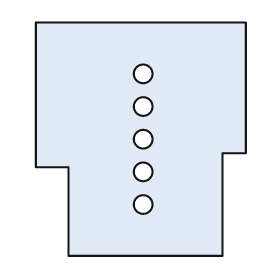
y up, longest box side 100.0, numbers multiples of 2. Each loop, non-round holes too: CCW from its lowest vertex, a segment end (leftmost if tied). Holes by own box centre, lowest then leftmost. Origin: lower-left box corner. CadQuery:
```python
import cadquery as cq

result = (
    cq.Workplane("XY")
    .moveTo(14.0, 0.0)
    .lineTo(80.0, 0.0)
    .lineTo(80.0, 44.0)
    .lineTo(90.0, 44.0)
    .lineTo(90.0, 100.0)
    .lineTo(0.0, 100.0)
    .lineTo(0.0, 38.0)
    .lineTo(14.0, 38.0)
    .close()
    .moveTo(46.0, 22.0)
    .circle(4.0)
    .moveTo(46.0, 36.0)
    .circle(4.0)
    .moveTo(46.0, 50.0)
    .circle(4.0)
    .moveTo(46.0, 64.0)
    .circle(4.0)
    .moveTo(46.0, 78.0)
    .circle(4.0)
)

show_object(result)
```